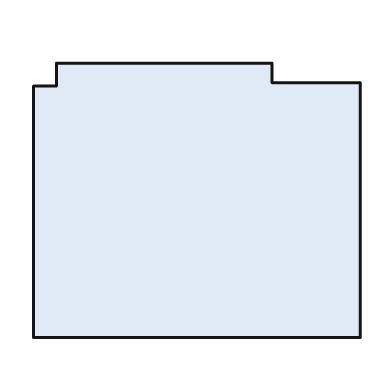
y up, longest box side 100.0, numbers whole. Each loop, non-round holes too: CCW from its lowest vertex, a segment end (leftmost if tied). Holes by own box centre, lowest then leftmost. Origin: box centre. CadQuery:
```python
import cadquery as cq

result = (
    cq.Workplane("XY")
    .moveTo(-50.0, -42.0)
    .lineTo(50.0, -42.0)
    .lineTo(50.0, 36.0)
    .lineTo(23.0, 36.0)
    .lineTo(23.0, 42.0)
    .lineTo(-43.0, 42.0)
    .lineTo(-43.0, 35.0)
    .lineTo(-50.0, 35.0)
    .close()
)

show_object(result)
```